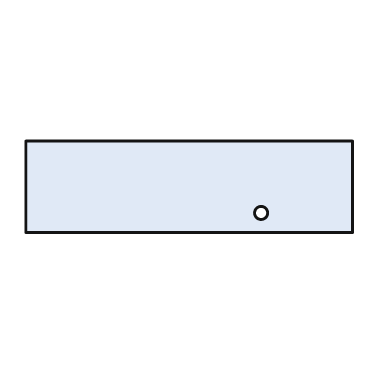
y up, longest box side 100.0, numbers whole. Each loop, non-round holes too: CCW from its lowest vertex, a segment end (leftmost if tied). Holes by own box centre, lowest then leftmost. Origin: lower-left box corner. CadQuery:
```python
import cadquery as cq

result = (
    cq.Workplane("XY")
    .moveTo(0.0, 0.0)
    .lineTo(100.0, 0.0)
    .lineTo(100.0, 28.0)
    .lineTo(0.0, 28.0)
    .close()
    .moveTo(72.0, 6.0)
    .circle(2.0)
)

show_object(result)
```